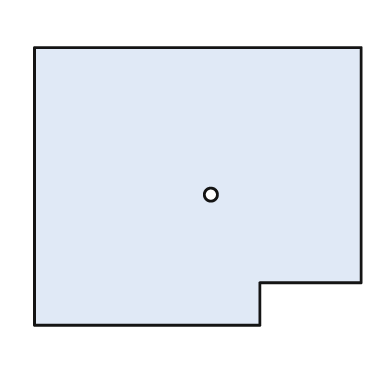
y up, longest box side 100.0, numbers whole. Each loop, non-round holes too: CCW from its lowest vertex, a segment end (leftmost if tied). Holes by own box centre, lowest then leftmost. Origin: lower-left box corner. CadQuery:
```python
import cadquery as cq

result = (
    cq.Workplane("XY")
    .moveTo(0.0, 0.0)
    .lineTo(69.0, 0.0)
    .lineTo(69.0, 13.0)
    .lineTo(100.0, 13.0)
    .lineTo(100.0, 85.0)
    .lineTo(0.0, 85.0)
    .close()
    .moveTo(54.0, 40.0)
    .circle(2.0)
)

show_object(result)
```